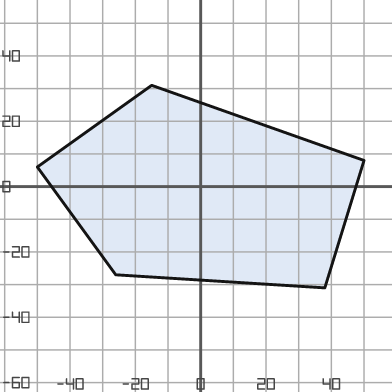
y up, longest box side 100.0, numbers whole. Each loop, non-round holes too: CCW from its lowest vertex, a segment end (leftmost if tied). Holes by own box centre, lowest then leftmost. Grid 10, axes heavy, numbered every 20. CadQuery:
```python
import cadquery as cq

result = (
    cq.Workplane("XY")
    .moveTo(38.0, -31.0)
    .lineTo(50.0, 8.0)
    .lineTo(-15.0, 31.0)
    .lineTo(-50.0, 6.0)
    .lineTo(-26.0, -27.0)
    .close()
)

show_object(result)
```